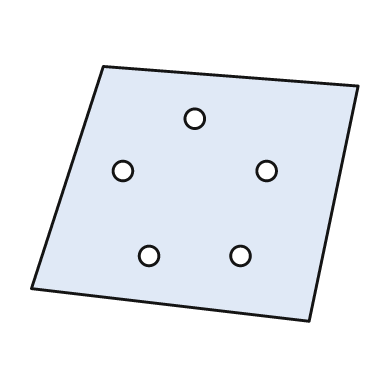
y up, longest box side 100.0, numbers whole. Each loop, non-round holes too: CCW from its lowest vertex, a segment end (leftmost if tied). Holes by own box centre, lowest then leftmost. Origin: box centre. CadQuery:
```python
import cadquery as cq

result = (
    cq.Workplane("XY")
    .moveTo(35.0, -39.0)
    .lineTo(50.0, 33.0)
    .lineTo(-28.0, 39.0)
    .lineTo(-50.0, -29.0)
    .close()
    .moveTo(-14.0, -19.0)
    .circle(3.0)
    .moveTo(14.0, -19.0)
    .circle(3.0)
    .moveTo(-22.0, 7.0)
    .circle(3.0)
    .moveTo(22.0, 7.0)
    .circle(3.0)
    .moveTo(0.0, 23.0)
    .circle(3.0)
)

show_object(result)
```